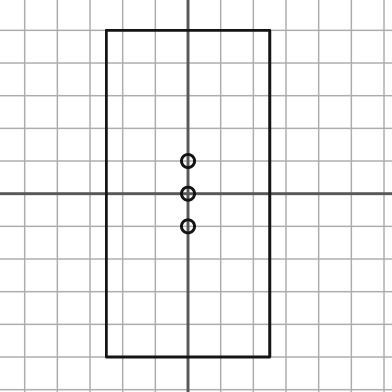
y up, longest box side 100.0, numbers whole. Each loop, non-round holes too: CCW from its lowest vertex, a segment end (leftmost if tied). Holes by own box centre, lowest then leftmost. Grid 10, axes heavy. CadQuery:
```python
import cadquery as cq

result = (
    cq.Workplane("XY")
    .moveTo(-25.0, -50.0)
    .lineTo(25.0, -50.0)
    .lineTo(25.0, 50.0)
    .lineTo(-25.0, 50.0)
    .close()
    .moveTo(0.0, -10.0)
    .circle(2.0)
    .moveTo(0.0, 0.0)
    .circle(2.0)
    .moveTo(0.0, 10.0)
    .circle(2.0)
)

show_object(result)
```